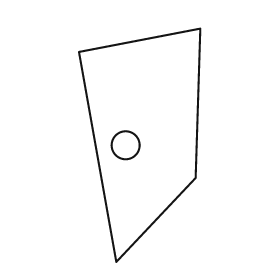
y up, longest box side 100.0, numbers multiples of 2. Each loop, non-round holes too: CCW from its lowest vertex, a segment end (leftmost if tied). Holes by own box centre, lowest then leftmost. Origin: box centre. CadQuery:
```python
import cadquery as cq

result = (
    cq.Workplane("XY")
    .moveTo(-10.0, -50.0)
    .lineTo(24.0, -14.0)
    .lineTo(26.0, 50.0)
    .lineTo(-26.0, 40.0)
    .close()
    .moveTo(-6.0, 0.0)
    .circle(6.0)
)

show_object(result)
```